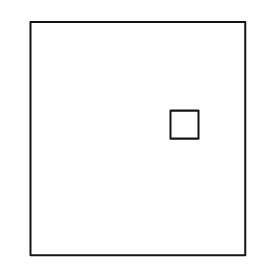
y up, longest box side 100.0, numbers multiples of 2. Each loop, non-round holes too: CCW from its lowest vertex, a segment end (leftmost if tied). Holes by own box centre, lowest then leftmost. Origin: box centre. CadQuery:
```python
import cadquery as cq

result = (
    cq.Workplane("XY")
    .moveTo(-46.0, -50.0)
    .lineTo(46.0, -50.0)
    .lineTo(46.0, 50.0)
    .lineTo(-46.0, 50.0)
    .close()
    .moveTo(14.0, 0.0)
    .lineTo(26.0, 0.0)
    .lineTo(26.0, 12.0)
    .lineTo(14.0, 12.0)
    .close()
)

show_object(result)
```